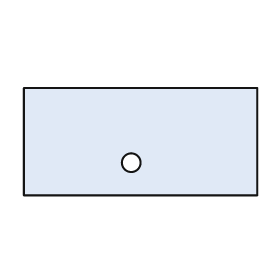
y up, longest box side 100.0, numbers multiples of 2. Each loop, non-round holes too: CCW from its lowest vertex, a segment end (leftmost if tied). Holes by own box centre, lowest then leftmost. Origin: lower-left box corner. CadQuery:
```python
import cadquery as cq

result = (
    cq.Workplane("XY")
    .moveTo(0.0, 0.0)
    .lineTo(100.0, 0.0)
    .lineTo(100.0, 46.0)
    .lineTo(0.0, 46.0)
    .close()
    .moveTo(46.0, 14.0)
    .circle(4.0)
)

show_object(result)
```